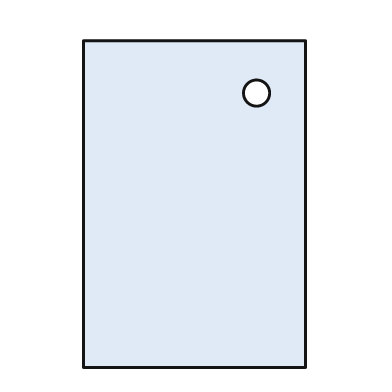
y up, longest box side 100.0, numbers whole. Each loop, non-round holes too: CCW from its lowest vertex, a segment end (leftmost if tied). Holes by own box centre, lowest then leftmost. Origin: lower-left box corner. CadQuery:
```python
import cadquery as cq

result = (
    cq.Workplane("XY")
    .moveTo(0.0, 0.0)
    .lineTo(68.0, 0.0)
    .lineTo(68.0, 100.0)
    .lineTo(0.0, 100.0)
    .close()
    .moveTo(53.0, 84.0)
    .circle(4.0)
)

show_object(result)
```